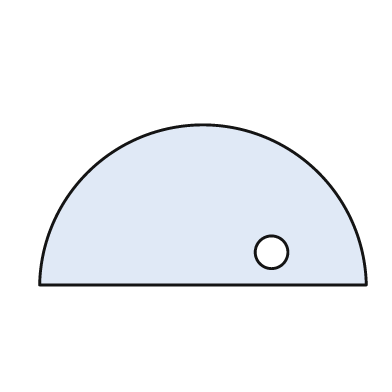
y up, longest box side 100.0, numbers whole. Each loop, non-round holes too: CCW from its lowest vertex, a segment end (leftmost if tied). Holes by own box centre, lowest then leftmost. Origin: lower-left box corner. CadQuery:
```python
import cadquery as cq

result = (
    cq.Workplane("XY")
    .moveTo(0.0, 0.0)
    .lineTo(100.0, 0.0)
    .threePointArc((50.0, 49.0), (0.0, 0.0))
    .close()
    .moveTo(71.0, 10.0)
    .circle(5.0)
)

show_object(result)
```